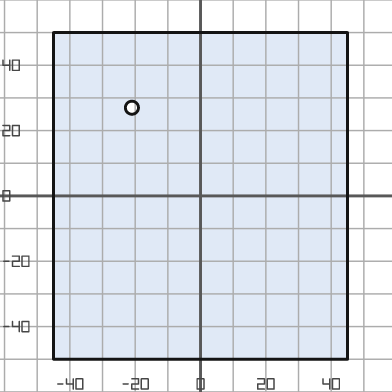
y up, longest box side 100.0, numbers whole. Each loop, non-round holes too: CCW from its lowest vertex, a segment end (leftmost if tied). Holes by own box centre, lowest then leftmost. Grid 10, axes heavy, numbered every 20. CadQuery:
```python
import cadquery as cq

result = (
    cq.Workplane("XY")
    .moveTo(-45.0, -50.0)
    .lineTo(45.0, -50.0)
    .lineTo(45.0, 50.0)
    .lineTo(-45.0, 50.0)
    .close()
    .moveTo(-21.0, 27.0)
    .circle(2.0)
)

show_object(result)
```